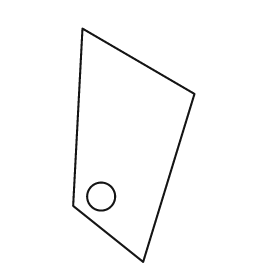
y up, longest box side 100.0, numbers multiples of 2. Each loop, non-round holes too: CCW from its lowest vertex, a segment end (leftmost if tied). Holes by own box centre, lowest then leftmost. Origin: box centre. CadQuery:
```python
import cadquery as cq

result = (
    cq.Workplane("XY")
    .moveTo(4.0, -50.0)
    .lineTo(26.0, 22.0)
    .lineTo(-22.0, 50.0)
    .lineTo(-26.0, -26.0)
    .close()
    .moveTo(-14.0, -22.0)
    .circle(6.0)
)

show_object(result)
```